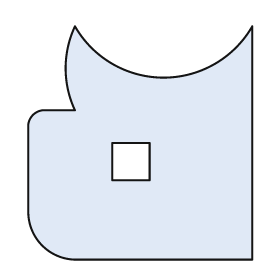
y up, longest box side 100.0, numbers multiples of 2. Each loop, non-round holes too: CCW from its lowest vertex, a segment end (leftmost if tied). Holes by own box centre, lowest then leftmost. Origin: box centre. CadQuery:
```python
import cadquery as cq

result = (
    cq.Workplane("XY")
    .moveTo(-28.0, -50.0)
    .lineTo(48.0, -50.0)
    .lineTo(48.0, 50.0)
    .threePointArc((10.0, 28.0), (-28.0, 50.0))
    .threePointArc((-32.0, 32.0), (-28.0, 14.0))
    .lineTo(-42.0, 14.0)
    .threePointArc((-46.0, 12.0), (-48.0, 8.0))
    .lineTo(-48.0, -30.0)
    .threePointArc((-42.0, -44.0), (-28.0, -50.0))
    .close()
    .moveTo(-12.0, -16.0)
    .lineTo(4.0, -16.0)
    .lineTo(4.0, 0.0)
    .lineTo(-12.0, 0.0)
    .close()
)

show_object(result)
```